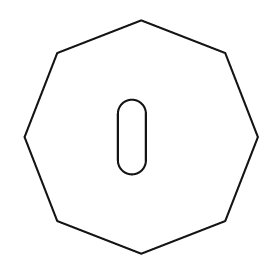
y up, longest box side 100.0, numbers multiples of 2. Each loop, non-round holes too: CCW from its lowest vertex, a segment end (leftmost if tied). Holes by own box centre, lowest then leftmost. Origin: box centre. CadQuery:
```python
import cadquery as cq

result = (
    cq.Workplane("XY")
    .moveTo(0.0, -50.0)
    .lineTo(36.0, -36.0)
    .lineTo(50.0, 0.0)
    .lineTo(36.0, 36.0)
    .lineTo(0.0, 50.0)
    .lineTo(-36.0, 36.0)
    .lineTo(-50.0, 0.0)
    .lineTo(-36.0, -36.0)
    .close()
    .moveTo(-10.0, -10.0)
    .threePointArc((-4.0, -16.0), (2.0, -10.0))
    .lineTo(2.0, 10.0)
    .threePointArc((-4.0, 16.0), (-10.0, 10.0))
    .close()
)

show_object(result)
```